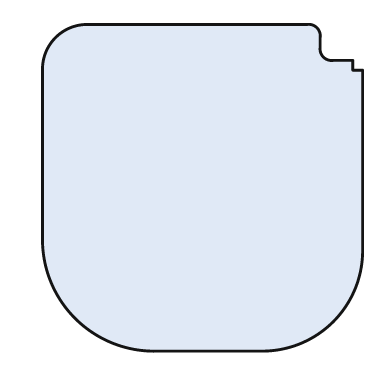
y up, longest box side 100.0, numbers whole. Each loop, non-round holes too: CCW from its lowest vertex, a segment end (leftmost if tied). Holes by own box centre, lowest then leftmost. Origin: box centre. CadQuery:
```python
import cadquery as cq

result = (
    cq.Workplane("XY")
    .moveTo(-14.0, -50.0)
    .lineTo(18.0, -50.0)
    .threePointArc((40.0, -41.0), (49.0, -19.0))
    .lineTo(49.0, 36.0)
    .lineTo(46.0, 36.0)
    .lineTo(46.0, 39.0)
    .lineTo(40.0, 39.0)
    .threePointArc((37.0, 40.0), (36.0, 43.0))
    .lineTo(36.0, 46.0)
    .threePointArc((35.0, 49.0), (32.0, 50.0))
    .lineTo(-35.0, 50.0)
    .threePointArc((-45.0, 46.0), (-49.0, 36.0))
    .lineTo(-49.0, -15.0)
    .threePointArc((-39.0, -40.0), (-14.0, -50.0))
    .close()
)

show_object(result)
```